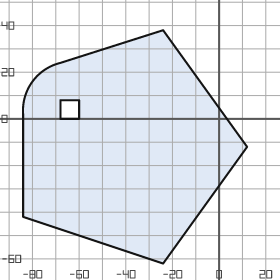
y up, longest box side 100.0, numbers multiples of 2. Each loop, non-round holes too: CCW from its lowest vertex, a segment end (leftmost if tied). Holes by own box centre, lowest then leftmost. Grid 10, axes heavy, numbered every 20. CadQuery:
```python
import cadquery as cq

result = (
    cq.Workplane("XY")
    .moveTo(-24.0, -62.0)
    .lineTo(12.0, -12.0)
    .lineTo(-24.0, 38.0)
    .lineTo(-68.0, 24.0)
    .threePointArc((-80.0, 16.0), (-84.0, 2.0))
    .lineTo(-84.0, -42.0)
    .close()
    .moveTo(-68.0, 0.0)
    .lineTo(-60.0, 0.0)
    .lineTo(-60.0, 8.0)
    .lineTo(-68.0, 8.0)
    .close()
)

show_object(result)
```